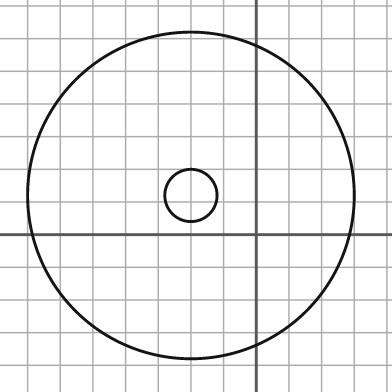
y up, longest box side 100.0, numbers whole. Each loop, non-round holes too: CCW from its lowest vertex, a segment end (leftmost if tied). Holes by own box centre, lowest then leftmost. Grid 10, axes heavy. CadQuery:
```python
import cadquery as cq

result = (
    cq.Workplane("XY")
    .moveTo(-20.0, 12.0)
    .circle(50.0)
    .moveTo(-20.0, 12.0)
    .circle(8.0)
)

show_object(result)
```